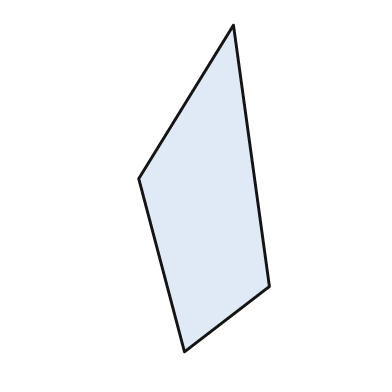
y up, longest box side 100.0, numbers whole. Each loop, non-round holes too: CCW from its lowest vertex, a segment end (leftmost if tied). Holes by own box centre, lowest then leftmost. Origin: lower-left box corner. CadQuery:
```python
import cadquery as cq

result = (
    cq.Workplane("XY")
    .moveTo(14.0, 0.0)
    .lineTo(40.0, 20.0)
    .lineTo(29.0, 100.0)
    .lineTo(0.0, 53.0)
    .close()
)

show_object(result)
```